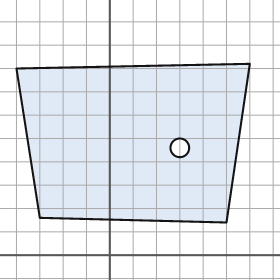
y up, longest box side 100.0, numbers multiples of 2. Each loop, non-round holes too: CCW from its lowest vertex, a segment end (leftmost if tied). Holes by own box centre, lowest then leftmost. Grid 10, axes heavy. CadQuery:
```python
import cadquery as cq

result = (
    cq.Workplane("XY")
    .moveTo(50.0, 14.0)
    .lineTo(60.0, 82.0)
    .lineTo(-40.0, 80.0)
    .lineTo(-30.0, 16.0)
    .close()
    .moveTo(30.0, 46.0)
    .circle(4.0)
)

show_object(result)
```